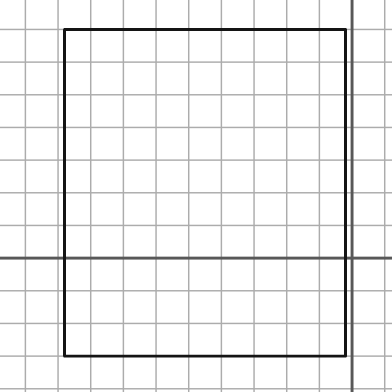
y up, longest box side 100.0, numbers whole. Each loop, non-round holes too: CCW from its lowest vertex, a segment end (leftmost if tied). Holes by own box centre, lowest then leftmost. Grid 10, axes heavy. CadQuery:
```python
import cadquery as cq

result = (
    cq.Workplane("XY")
    .moveTo(-88.0, -30.0)
    .lineTo(-2.0, -30.0)
    .lineTo(-2.0, 70.0)
    .lineTo(-88.0, 70.0)
    .close()
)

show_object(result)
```